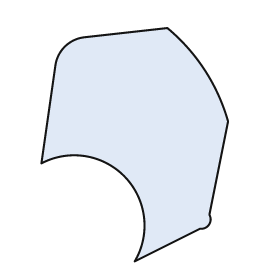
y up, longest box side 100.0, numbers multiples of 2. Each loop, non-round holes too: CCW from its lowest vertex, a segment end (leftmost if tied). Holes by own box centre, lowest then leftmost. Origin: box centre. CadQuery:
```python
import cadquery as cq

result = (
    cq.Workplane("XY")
    .moveTo(0.0, -50.0)
    .lineTo(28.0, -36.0)
    .threePointArc((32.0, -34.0), (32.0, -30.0))
    .lineTo(40.0, 10.0)
    .threePointArc((30.0, 32.0), (14.0, 50.0))
    .lineTo(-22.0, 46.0)
    .threePointArc((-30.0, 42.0), (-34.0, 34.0))
    .lineTo(-40.0, -8.0)
    .threePointArc((-4.0, -14.0), (0.0, -50.0))
    .close()
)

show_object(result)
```